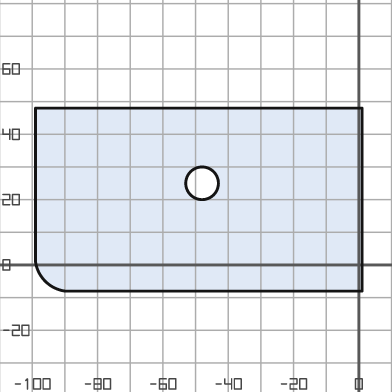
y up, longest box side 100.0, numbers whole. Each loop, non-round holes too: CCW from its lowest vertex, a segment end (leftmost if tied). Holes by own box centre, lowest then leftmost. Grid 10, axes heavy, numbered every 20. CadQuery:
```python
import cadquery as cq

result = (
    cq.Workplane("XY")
    .moveTo(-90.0, -8.0)
    .lineTo(1.0, -8.0)
    .lineTo(1.0, 48.0)
    .lineTo(-99.0, 48.0)
    .lineTo(-99.0, 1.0)
    .threePointArc((-96.0, -5.0), (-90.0, -8.0))
    .close()
    .moveTo(-48.0, 25.0)
    .circle(5.0)
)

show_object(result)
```